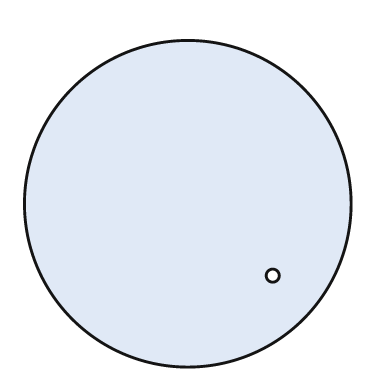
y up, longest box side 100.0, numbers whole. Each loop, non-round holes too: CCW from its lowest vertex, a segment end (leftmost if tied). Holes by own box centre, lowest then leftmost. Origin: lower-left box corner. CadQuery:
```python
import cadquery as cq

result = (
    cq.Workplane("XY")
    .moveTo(50.0, 50.0)
    .circle(50.0)
    .moveTo(76.0, 28.0)
    .circle(2.0)
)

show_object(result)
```